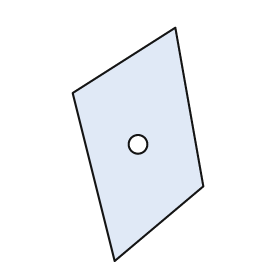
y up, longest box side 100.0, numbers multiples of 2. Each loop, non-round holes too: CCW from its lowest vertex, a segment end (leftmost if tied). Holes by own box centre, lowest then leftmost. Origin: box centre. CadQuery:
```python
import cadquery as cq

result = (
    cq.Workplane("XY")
    .moveTo(-10.0, -50.0)
    .lineTo(28.0, -18.0)
    .lineTo(16.0, 50.0)
    .lineTo(-28.0, 22.0)
    .close()
    .moveTo(0.0, 0.0)
    .circle(4.0)
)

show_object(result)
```